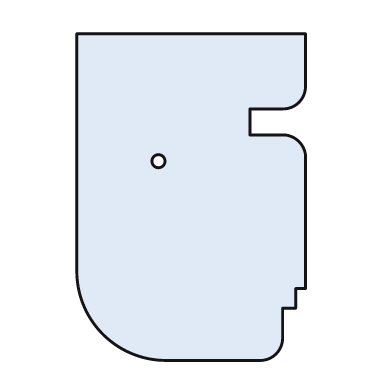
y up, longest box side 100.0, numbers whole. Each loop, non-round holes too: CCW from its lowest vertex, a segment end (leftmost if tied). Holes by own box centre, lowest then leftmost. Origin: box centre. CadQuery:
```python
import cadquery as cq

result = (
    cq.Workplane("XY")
    .moveTo(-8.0, -50.0)
    .lineTo(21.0, -50.0)
    .threePointArc((26.0, -48.0), (28.0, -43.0))
    .lineTo(28.0, -34.0)
    .lineTo(32.0, -34.0)
    .lineTo(32.0, -28.0)
    .lineTo(35.0, -28.0)
    .lineTo(35.0, 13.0)
    .threePointArc((33.0, 17.0), (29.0, 19.0))
    .lineTo(18.0, 19.0)
    .lineTo(18.0, 27.0)
    .lineTo(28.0, 27.0)
    .threePointArc((33.0, 29.0), (35.0, 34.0))
    .lineTo(35.0, 50.0)
    .lineTo(-35.0, 50.0)
    .lineTo(-35.0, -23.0)
    .threePointArc((-27.0, -42.0), (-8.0, -50.0))
    .close()
    .moveTo(-10.0, 11.0)
    .circle(2.0)
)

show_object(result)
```